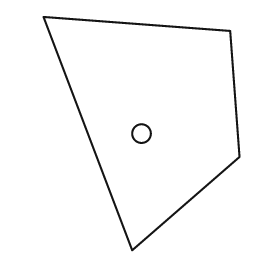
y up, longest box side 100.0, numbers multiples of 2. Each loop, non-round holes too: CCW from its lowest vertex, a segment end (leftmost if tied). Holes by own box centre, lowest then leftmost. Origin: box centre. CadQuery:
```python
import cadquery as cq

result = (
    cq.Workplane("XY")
    .moveTo(-4.0, -50.0)
    .lineTo(42.0, -10.0)
    .lineTo(38.0, 44.0)
    .lineTo(-42.0, 50.0)
    .close()
    .moveTo(0.0, 0.0)
    .circle(4.0)
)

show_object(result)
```